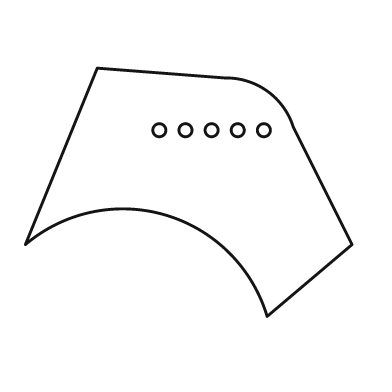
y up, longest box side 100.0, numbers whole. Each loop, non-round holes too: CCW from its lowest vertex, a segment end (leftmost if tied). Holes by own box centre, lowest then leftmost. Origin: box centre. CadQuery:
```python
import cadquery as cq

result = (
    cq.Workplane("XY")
    .moveTo(24.0, -38.0)
    .lineTo(50.0, -16.0)
    .lineTo(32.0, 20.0)
    .threePointArc((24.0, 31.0), (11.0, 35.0))
    .lineTo(-28.0, 38.0)
    .lineTo(-50.0, -16.0)
    .threePointArc((-7.0, -7.0), (24.0, -38.0))
    .close()
    .moveTo(-9.0, 19.0)
    .circle(2.0)
    .moveTo(-1.0, 19.0)
    .circle(2.0)
    .moveTo(7.0, 19.0)
    .circle(2.0)
    .moveTo(15.0, 19.0)
    .circle(2.0)
    .moveTo(23.0, 19.0)
    .circle(2.0)
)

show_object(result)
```